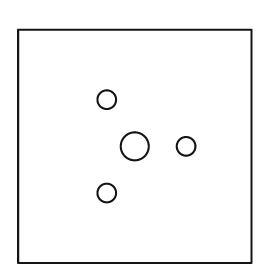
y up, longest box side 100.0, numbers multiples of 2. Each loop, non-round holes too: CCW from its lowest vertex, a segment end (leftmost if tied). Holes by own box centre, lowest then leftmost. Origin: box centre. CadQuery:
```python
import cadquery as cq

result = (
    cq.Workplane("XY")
    .moveTo(-50.0, -50.0)
    .lineTo(50.0, -50.0)
    .lineTo(50.0, 50.0)
    .lineTo(-50.0, 50.0)
    .close()
    .moveTo(-12.0, -20.0)
    .circle(4.0)
    .moveTo(0.0, 0.0)
    .circle(6.0)
    .moveTo(22.0, 0.0)
    .circle(4.0)
    .moveTo(-12.0, 20.0)
    .circle(4.0)
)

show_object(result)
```